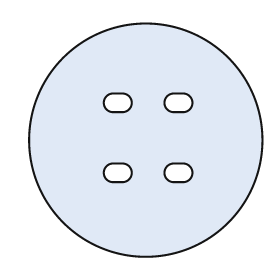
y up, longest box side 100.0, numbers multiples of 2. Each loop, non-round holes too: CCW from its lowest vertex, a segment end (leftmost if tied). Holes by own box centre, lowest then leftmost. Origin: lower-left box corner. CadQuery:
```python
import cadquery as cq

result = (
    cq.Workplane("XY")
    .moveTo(50.0, 50.0)
    .circle(50.0)
    .moveTo(36.0, 32.0)
    .lineTo(40.0, 32.0)
    .threePointArc((44.0, 36.0), (40.0, 40.0))
    .lineTo(36.0, 40.0)
    .threePointArc((32.0, 36.0), (36.0, 32.0))
    .close()
    .moveTo(62.0, 32.0)
    .lineTo(66.0, 32.0)
    .threePointArc((70.0, 36.0), (66.0, 40.0))
    .lineTo(62.0, 40.0)
    .threePointArc((58.0, 36.0), (62.0, 32.0))
    .close()
    .moveTo(36.0, 62.0)
    .lineTo(40.0, 62.0)
    .threePointArc((44.0, 66.0), (40.0, 70.0))
    .lineTo(36.0, 70.0)
    .threePointArc((32.0, 66.0), (36.0, 62.0))
    .close()
    .moveTo(62.0, 62.0)
    .lineTo(66.0, 62.0)
    .threePointArc((70.0, 66.0), (66.0, 70.0))
    .lineTo(62.0, 70.0)
    .threePointArc((58.0, 66.0), (62.0, 62.0))
    .close()
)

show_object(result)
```